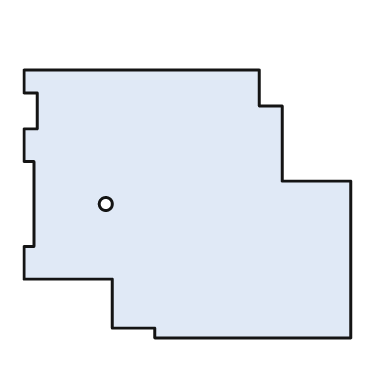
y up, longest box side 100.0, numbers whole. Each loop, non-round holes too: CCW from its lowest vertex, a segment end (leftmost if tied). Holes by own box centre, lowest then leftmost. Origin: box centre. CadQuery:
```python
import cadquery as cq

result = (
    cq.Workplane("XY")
    .moveTo(-10.0, -41.0)
    .lineTo(50.0, -41.0)
    .lineTo(50.0, 7.0)
    .lineTo(29.0, 7.0)
    .lineTo(29.0, 30.0)
    .lineTo(22.0, 30.0)
    .lineTo(22.0, 41.0)
    .lineTo(-50.0, 41.0)
    .lineTo(-50.0, 34.0)
    .lineTo(-46.0, 34.0)
    .lineTo(-46.0, 23.0)
    .lineTo(-50.0, 23.0)
    .lineTo(-50.0, 13.0)
    .lineTo(-47.0, 13.0)
    .lineTo(-47.0, -13.0)
    .lineTo(-50.0, -13.0)
    .lineTo(-50.0, -23.0)
    .lineTo(-23.0, -23.0)
    .lineTo(-23.0, -38.0)
    .lineTo(-10.0, -38.0)
    .close()
    .moveTo(-25.0, 0.0)
    .circle(2.0)
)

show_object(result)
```